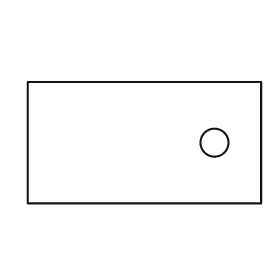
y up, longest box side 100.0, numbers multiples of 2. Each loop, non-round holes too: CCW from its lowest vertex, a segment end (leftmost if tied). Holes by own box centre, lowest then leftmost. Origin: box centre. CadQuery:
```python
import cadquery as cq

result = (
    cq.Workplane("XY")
    .moveTo(-50.0, -26.0)
    .lineTo(50.0, -26.0)
    .lineTo(50.0, 26.0)
    .lineTo(-50.0, 26.0)
    .close()
    .moveTo(30.0, 0.0)
    .circle(6.0)
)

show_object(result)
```